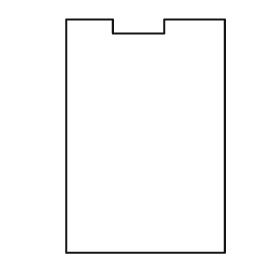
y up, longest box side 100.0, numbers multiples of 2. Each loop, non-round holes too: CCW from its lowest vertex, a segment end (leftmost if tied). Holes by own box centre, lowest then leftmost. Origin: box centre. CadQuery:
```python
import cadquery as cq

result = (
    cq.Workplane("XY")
    .moveTo(-34.0, -50.0)
    .lineTo(34.0, -50.0)
    .lineTo(34.0, 50.0)
    .lineTo(8.0, 50.0)
    .lineTo(8.0, 44.0)
    .lineTo(-14.0, 44.0)
    .lineTo(-14.0, 50.0)
    .lineTo(-34.0, 50.0)
    .close()
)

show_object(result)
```